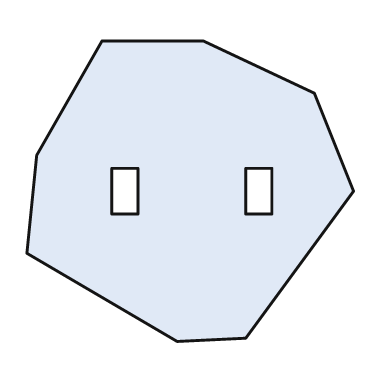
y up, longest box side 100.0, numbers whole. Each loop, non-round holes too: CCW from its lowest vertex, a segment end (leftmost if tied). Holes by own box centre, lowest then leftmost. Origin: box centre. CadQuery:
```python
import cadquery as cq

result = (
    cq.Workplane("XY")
    .moveTo(-4.0, -46.0)
    .lineTo(17.0, -45.0)
    .lineTo(50.0, 0.0)
    .lineTo(38.0, 30.0)
    .lineTo(4.0, 46.0)
    .lineTo(-27.0, 46.0)
    .lineTo(-47.0, 11.0)
    .lineTo(-50.0, -19.0)
    .close()
    .moveTo(-24.0, -7.0)
    .lineTo(-16.0, -7.0)
    .lineTo(-16.0, 7.0)
    .lineTo(-24.0, 7.0)
    .close()
    .moveTo(17.0, -7.0)
    .lineTo(25.0, -7.0)
    .lineTo(25.0, 7.0)
    .lineTo(17.0, 7.0)
    .close()
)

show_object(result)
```